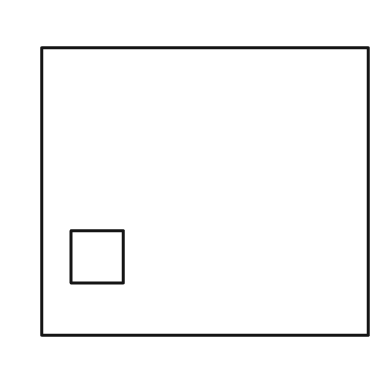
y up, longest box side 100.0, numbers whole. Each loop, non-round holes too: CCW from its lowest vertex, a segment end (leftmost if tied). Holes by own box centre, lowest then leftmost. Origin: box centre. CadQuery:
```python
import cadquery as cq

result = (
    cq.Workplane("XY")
    .moveTo(-50.0, -44.0)
    .lineTo(50.0, -44.0)
    .lineTo(50.0, 44.0)
    .lineTo(-50.0, 44.0)
    .close()
    .moveTo(-41.0, -28.0)
    .lineTo(-25.0, -28.0)
    .lineTo(-25.0, -12.0)
    .lineTo(-41.0, -12.0)
    .close()
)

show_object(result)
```